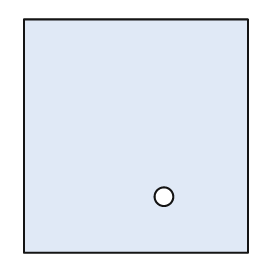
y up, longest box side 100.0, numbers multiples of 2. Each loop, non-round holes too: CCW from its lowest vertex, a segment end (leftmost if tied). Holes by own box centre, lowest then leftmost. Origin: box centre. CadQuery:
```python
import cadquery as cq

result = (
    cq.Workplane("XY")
    .moveTo(-48.0, -50.0)
    .lineTo(48.0, -50.0)
    .lineTo(48.0, 50.0)
    .lineTo(-48.0, 50.0)
    .close()
    .moveTo(12.0, -26.0)
    .circle(4.0)
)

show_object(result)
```